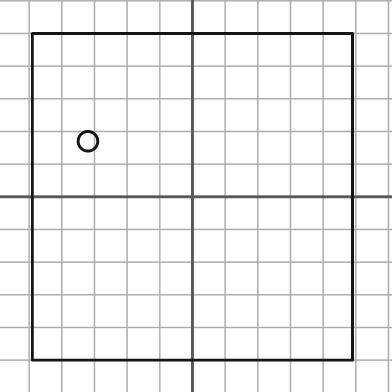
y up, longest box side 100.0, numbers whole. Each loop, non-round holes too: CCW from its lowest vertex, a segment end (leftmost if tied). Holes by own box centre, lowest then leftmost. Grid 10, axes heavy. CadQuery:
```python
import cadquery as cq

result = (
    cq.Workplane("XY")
    .moveTo(-49.0, -50.0)
    .lineTo(49.0, -50.0)
    .lineTo(49.0, 50.0)
    .lineTo(-49.0, 50.0)
    .close()
    .moveTo(-32.0, 17.0)
    .circle(3.0)
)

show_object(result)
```